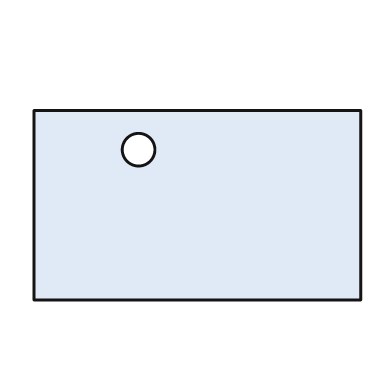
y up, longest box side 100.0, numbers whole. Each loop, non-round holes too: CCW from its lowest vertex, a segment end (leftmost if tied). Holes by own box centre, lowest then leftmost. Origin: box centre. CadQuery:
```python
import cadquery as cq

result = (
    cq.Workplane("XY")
    .moveTo(-50.0, -29.0)
    .lineTo(50.0, -29.0)
    .lineTo(50.0, 29.0)
    .lineTo(-50.0, 29.0)
    .close()
    .moveTo(-18.0, 17.0)
    .circle(5.0)
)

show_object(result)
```